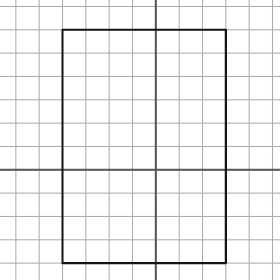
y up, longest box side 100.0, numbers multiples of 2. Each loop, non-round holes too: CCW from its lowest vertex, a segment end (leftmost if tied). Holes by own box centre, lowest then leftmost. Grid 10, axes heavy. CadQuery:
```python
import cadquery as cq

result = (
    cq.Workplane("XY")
    .moveTo(-40.0, -40.0)
    .lineTo(30.0, -40.0)
    .lineTo(30.0, 60.0)
    .lineTo(-40.0, 60.0)
    .close()
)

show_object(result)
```